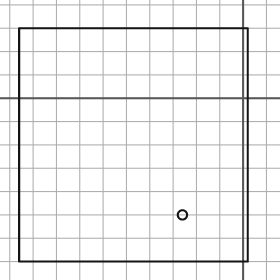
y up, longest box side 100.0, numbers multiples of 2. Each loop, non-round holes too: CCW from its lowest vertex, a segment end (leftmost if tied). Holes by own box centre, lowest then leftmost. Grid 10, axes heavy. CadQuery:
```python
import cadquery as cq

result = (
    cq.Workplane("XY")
    .moveTo(-96.0, -70.0)
    .lineTo(2.0, -70.0)
    .lineTo(2.0, 30.0)
    .lineTo(-96.0, 30.0)
    .close()
    .moveTo(-26.0, -50.0)
    .circle(2.0)
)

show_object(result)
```